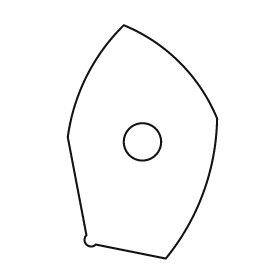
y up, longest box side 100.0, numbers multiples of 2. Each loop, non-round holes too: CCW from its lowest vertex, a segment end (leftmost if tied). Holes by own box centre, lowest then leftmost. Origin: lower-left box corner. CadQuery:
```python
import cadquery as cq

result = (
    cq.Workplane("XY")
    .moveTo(42.0, 0.0)
    .threePointArc((58.0, 28.0), (64.0, 60.0))
    .threePointArc((48.0, 84.0), (24.0, 100.0))
    .threePointArc((8.0, 78.0), (0.0, 52.0))
    .lineTo(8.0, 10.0)
    .threePointArc((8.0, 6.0), (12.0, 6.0))
    .close()
    .moveTo(32.0, 50.0)
    .circle(8.0)
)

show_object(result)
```